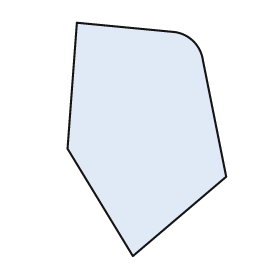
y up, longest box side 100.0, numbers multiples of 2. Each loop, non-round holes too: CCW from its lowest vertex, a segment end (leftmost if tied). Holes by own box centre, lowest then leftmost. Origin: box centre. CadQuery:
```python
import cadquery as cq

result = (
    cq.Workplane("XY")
    .moveTo(-6.0, -50.0)
    .lineTo(34.0, -16.0)
    .lineTo(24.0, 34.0)
    .threePointArc((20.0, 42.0), (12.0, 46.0))
    .lineTo(-30.0, 50.0)
    .lineTo(-34.0, -4.0)
    .close()
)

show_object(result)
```